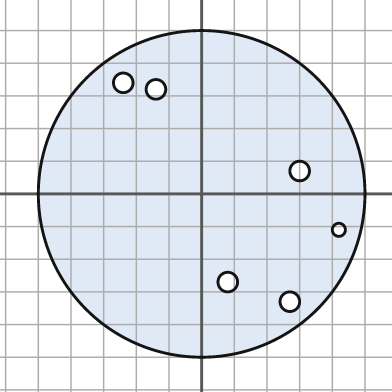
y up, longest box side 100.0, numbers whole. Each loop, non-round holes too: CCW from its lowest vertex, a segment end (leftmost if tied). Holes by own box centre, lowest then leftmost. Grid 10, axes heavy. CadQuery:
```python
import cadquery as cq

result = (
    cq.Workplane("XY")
    .moveTo(0.0, 0.0)
    .circle(50.0)
    .moveTo(27.0, -33.0)
    .circle(3.0)
    .moveTo(8.0, -27.0)
    .circle(3.0)
    .moveTo(42.0, -11.0)
    .circle(2.0)
    .moveTo(30.0, 7.0)
    .circle(3.0)
    .moveTo(-14.0, 32.0)
    .circle(3.0)
    .moveTo(-24.0, 34.0)
    .circle(3.0)
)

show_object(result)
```